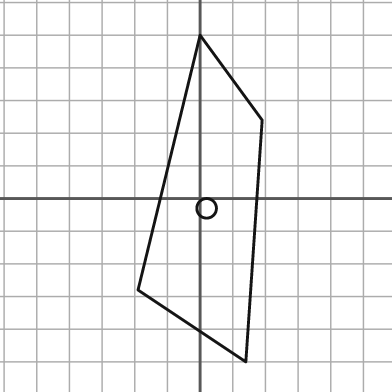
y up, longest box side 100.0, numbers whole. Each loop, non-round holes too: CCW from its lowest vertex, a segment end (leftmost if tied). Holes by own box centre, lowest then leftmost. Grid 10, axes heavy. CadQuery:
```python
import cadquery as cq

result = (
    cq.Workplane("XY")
    .moveTo(14.0, -50.0)
    .lineTo(19.0, 24.0)
    .lineTo(0.0, 50.0)
    .lineTo(-19.0, -28.0)
    .close()
    .moveTo(2.0, -3.0)
    .circle(3.0)
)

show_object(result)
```